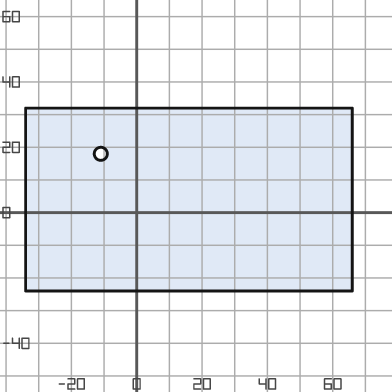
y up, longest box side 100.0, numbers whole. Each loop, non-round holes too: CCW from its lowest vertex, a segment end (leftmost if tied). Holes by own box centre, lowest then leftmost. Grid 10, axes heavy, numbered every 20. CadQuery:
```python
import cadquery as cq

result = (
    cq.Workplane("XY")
    .moveTo(-34.0, -24.0)
    .lineTo(66.0, -24.0)
    .lineTo(66.0, 32.0)
    .lineTo(-34.0, 32.0)
    .close()
    .moveTo(-11.0, 18.0)
    .circle(2.0)
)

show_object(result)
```